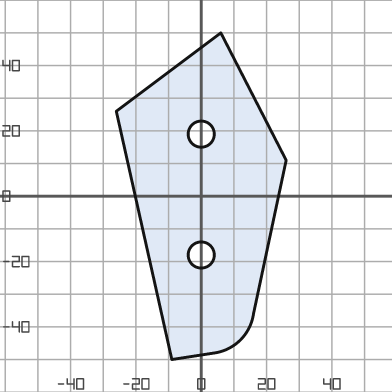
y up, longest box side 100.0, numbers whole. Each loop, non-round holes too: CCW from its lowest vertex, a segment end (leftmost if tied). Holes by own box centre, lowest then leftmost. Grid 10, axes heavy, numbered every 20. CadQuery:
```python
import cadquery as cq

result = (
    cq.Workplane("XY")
    .moveTo(-9.0, -50.0)
    .lineTo(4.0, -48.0)
    .threePointArc((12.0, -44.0), (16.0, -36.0))
    .lineTo(26.0, 11.0)
    .lineTo(6.0, 50.0)
    .lineTo(-26.0, 26.0)
    .close()
    .moveTo(0.0, -18.0)
    .circle(4.0)
    .moveTo(0.0, 19.0)
    .circle(4.0)
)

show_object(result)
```